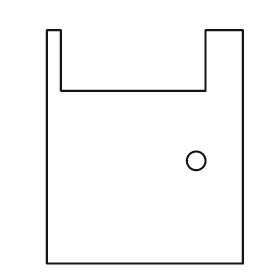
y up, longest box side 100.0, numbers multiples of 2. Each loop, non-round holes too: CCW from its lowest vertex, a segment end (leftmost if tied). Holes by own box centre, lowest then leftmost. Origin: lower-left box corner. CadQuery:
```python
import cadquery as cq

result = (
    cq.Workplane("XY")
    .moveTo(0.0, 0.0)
    .lineTo(84.0, 0.0)
    .lineTo(84.0, 100.0)
    .lineTo(68.0, 100.0)
    .lineTo(68.0, 74.0)
    .lineTo(6.0, 74.0)
    .lineTo(6.0, 100.0)
    .lineTo(0.0, 100.0)
    .close()
    .moveTo(64.0, 44.0)
    .circle(4.0)
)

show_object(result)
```